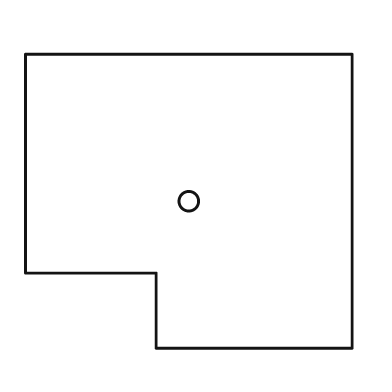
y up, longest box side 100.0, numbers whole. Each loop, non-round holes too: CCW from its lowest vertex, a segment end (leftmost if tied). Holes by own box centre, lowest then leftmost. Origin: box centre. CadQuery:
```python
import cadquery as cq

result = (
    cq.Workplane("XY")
    .moveTo(-10.0, -45.0)
    .lineTo(50.0, -45.0)
    .lineTo(50.0, 45.0)
    .lineTo(-50.0, 45.0)
    .lineTo(-50.0, -22.0)
    .lineTo(-10.0, -22.0)
    .close()
    .moveTo(0.0, 0.0)
    .circle(3.0)
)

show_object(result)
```